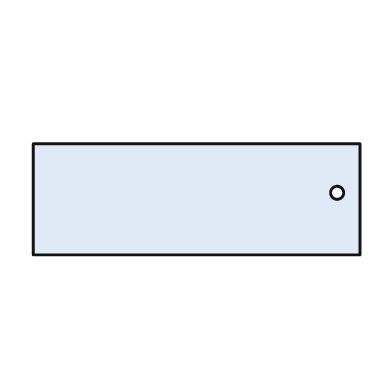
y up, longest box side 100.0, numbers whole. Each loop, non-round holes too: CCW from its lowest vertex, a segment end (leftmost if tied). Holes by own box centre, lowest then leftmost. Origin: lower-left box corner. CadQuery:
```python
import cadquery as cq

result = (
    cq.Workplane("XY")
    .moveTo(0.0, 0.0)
    .lineTo(100.0, 0.0)
    .lineTo(100.0, 34.0)
    .lineTo(0.0, 34.0)
    .close()
    .moveTo(93.0, 19.0)
    .circle(2.0)
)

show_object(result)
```